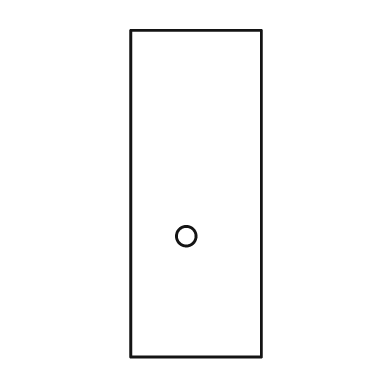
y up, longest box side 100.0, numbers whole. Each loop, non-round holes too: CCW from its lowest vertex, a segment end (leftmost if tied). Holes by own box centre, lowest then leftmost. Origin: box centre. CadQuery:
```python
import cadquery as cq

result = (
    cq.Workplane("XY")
    .moveTo(-20.0, -50.0)
    .lineTo(20.0, -50.0)
    .lineTo(20.0, 50.0)
    .lineTo(-20.0, 50.0)
    .close()
    .moveTo(-3.0, -13.0)
    .circle(3.0)
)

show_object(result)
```